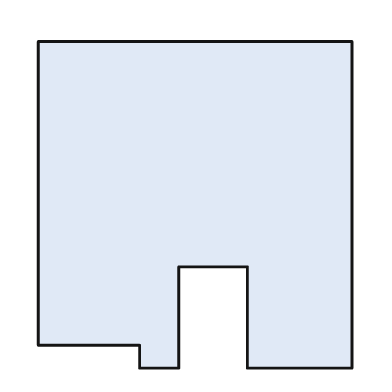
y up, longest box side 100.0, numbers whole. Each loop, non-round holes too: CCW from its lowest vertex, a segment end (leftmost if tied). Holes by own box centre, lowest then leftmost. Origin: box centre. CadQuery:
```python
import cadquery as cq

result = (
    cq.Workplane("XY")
    .moveTo(-17.0, -50.0)
    .lineTo(-5.0, -50.0)
    .lineTo(-5.0, -19.0)
    .lineTo(16.0, -19.0)
    .lineTo(16.0, -50.0)
    .lineTo(48.0, -50.0)
    .lineTo(48.0, 50.0)
    .lineTo(-48.0, 50.0)
    .lineTo(-48.0, -43.0)
    .lineTo(-17.0, -43.0)
    .close()
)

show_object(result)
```